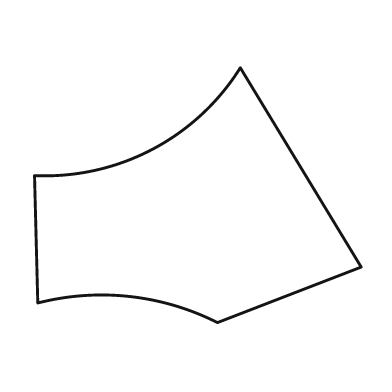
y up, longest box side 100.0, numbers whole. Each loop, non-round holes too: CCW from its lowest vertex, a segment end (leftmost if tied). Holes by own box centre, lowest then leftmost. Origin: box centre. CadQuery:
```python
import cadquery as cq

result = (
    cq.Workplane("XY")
    .moveTo(6.0, -39.0)
    .lineTo(50.0, -22.0)
    .lineTo(13.0, 39.0)
    .threePointArc((-14.0, 14.0), (-50.0, 6.0))
    .lineTo(-49.0, -33.0)
    .threePointArc((-21.0, -31.0), (6.0, -39.0))
    .close()
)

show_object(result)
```